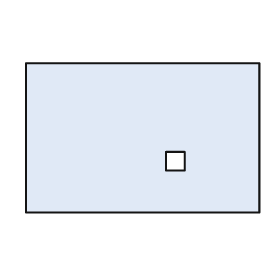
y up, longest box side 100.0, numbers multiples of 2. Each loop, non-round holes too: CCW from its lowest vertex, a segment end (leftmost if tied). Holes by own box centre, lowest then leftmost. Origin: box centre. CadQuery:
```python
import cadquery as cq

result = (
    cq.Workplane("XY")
    .moveTo(-50.0, -32.0)
    .lineTo(50.0, -32.0)
    .lineTo(50.0, 32.0)
    .lineTo(-50.0, 32.0)
    .close()
    .moveTo(10.0, -14.0)
    .lineTo(18.0, -14.0)
    .lineTo(18.0, -6.0)
    .lineTo(10.0, -6.0)
    .close()
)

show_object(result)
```